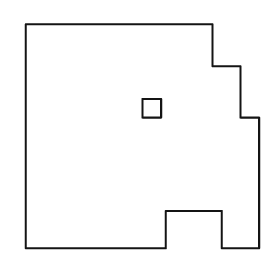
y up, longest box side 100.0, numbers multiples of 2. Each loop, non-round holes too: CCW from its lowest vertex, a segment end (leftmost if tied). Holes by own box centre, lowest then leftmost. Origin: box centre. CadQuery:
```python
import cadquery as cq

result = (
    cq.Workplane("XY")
    .moveTo(-50.0, -48.0)
    .lineTo(10.0, -48.0)
    .lineTo(10.0, -32.0)
    .lineTo(34.0, -32.0)
    .lineTo(34.0, -48.0)
    .lineTo(50.0, -48.0)
    .lineTo(50.0, 8.0)
    .lineTo(42.0, 8.0)
    .lineTo(42.0, 30.0)
    .lineTo(30.0, 30.0)
    .lineTo(30.0, 48.0)
    .lineTo(-50.0, 48.0)
    .close()
    .moveTo(0.0, 8.0)
    .lineTo(8.0, 8.0)
    .lineTo(8.0, 16.0)
    .lineTo(0.0, 16.0)
    .close()
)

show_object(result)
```